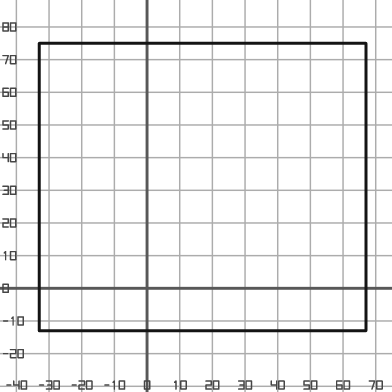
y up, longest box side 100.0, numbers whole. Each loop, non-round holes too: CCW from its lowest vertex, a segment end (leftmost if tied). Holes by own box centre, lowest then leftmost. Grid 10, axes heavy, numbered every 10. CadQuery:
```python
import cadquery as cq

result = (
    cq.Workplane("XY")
    .moveTo(-33.0, -13.0)
    .lineTo(67.0, -13.0)
    .lineTo(67.0, 75.0)
    .lineTo(-33.0, 75.0)
    .close()
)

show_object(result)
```